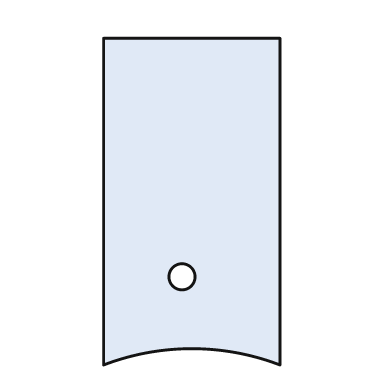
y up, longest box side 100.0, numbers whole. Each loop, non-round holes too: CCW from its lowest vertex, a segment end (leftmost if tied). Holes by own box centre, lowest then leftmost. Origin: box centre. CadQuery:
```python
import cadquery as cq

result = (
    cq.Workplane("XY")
    .moveTo(-27.0, -50.0)
    .threePointArc((0.0, -45.0), (27.0, -50.0))
    .lineTo(27.0, 50.0)
    .lineTo(-27.0, 50.0)
    .close()
    .moveTo(-3.0, -23.0)
    .circle(4.0)
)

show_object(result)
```